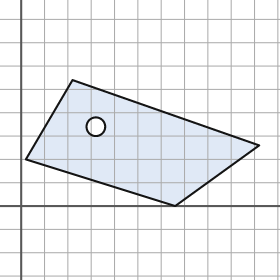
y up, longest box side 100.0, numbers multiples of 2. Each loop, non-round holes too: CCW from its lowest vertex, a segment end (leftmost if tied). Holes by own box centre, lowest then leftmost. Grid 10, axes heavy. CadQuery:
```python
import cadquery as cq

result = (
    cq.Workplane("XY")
    .moveTo(66.0, 0.0)
    .lineTo(102.0, 26.0)
    .lineTo(22.0, 54.0)
    .lineTo(2.0, 20.0)
    .close()
    .moveTo(32.0, 34.0)
    .circle(4.0)
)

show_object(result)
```